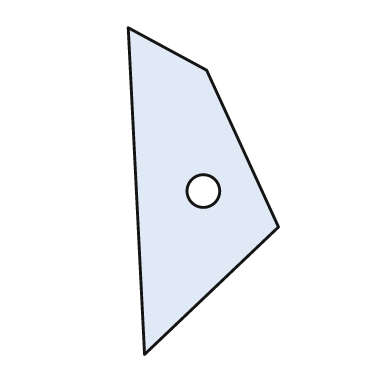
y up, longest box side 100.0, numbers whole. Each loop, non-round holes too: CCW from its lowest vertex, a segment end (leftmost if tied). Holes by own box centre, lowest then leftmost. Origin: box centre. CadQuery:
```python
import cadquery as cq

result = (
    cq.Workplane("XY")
    .moveTo(-18.0, -50.0)
    .lineTo(23.0, -11.0)
    .lineTo(1.0, 37.0)
    .lineTo(-23.0, 50.0)
    .close()
    .moveTo(0.0, 0.0)
    .circle(5.0)
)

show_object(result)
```